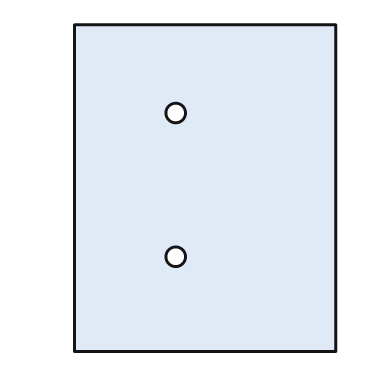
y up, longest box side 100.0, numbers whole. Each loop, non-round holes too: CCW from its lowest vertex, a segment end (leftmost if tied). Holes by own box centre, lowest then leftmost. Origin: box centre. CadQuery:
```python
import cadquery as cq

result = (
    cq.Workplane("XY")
    .moveTo(-40.0, -50.0)
    .lineTo(40.0, -50.0)
    .lineTo(40.0, 50.0)
    .lineTo(-40.0, 50.0)
    .close()
    .moveTo(-9.0, -21.0)
    .circle(3.0)
    .moveTo(-9.0, 23.0)
    .circle(3.0)
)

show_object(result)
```